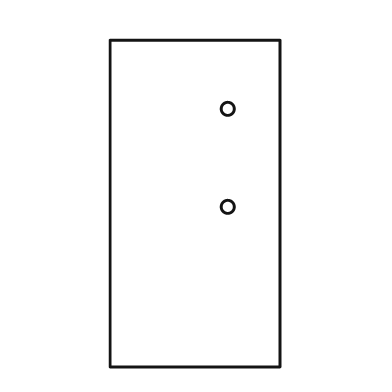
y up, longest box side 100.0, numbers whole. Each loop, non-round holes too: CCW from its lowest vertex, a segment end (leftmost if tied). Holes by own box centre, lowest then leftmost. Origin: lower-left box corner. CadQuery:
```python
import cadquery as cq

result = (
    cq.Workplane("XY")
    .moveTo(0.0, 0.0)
    .lineTo(52.0, 0.0)
    .lineTo(52.0, 100.0)
    .lineTo(0.0, 100.0)
    .close()
    .moveTo(36.0, 49.0)
    .circle(2.0)
    .moveTo(36.0, 79.0)
    .circle(2.0)
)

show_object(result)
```